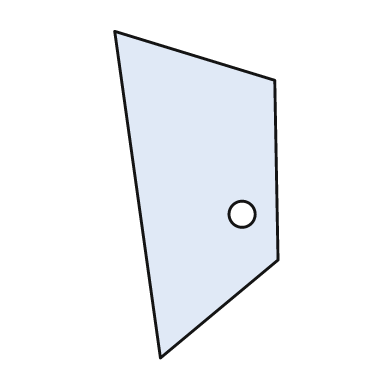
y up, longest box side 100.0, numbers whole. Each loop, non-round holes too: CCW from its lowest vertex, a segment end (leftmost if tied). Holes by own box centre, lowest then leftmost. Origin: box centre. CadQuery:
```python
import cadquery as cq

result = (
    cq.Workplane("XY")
    .moveTo(-11.0, -50.0)
    .lineTo(25.0, -20.0)
    .lineTo(24.0, 35.0)
    .lineTo(-25.0, 50.0)
    .close()
    .moveTo(14.0, -6.0)
    .circle(4.0)
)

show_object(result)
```